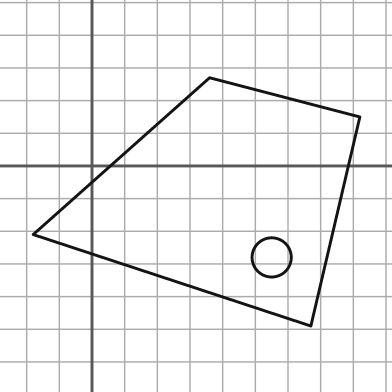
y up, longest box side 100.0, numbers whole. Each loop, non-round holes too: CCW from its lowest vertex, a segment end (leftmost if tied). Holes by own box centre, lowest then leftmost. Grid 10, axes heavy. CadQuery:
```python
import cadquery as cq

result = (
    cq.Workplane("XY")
    .moveTo(67.0, -49.0)
    .lineTo(82.0, 15.0)
    .lineTo(36.0, 27.0)
    .lineTo(-18.0, -21.0)
    .close()
    .moveTo(55.0, -28.0)
    .circle(6.0)
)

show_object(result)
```